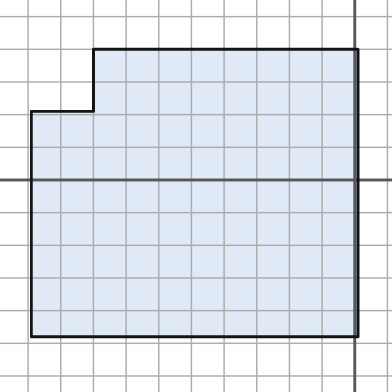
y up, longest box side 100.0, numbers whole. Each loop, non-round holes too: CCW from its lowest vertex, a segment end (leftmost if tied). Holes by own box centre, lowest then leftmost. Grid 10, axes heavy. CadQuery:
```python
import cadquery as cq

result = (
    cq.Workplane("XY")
    .moveTo(-99.0, -48.0)
    .lineTo(1.0, -48.0)
    .lineTo(1.0, 40.0)
    .lineTo(-80.0, 40.0)
    .lineTo(-80.0, 21.0)
    .lineTo(-99.0, 21.0)
    .close()
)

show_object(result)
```